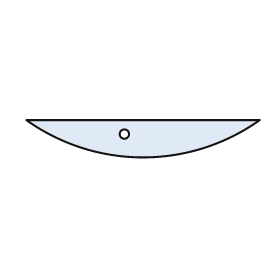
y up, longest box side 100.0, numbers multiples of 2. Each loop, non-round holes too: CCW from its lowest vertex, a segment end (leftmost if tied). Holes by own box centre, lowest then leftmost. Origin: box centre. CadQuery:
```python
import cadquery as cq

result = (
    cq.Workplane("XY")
    .moveTo(-50.0, 8.0)
    .threePointArc((0.0, -8.0), (50.0, 8.0))
    .close()
    .moveTo(-8.0, 2.0)
    .circle(2.0)
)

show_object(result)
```